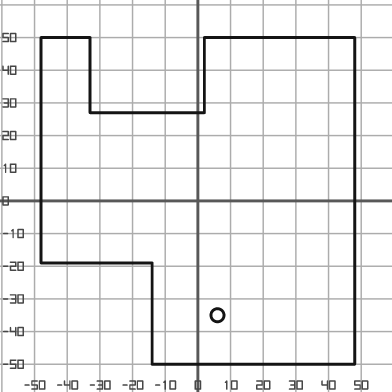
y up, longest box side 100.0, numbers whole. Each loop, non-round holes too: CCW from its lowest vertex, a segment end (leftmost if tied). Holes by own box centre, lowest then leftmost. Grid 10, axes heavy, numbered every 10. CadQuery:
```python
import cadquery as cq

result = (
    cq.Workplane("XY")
    .moveTo(-14.0, -50.0)
    .lineTo(48.0, -50.0)
    .lineTo(48.0, 50.0)
    .lineTo(2.0, 50.0)
    .lineTo(2.0, 27.0)
    .lineTo(-33.0, 27.0)
    .lineTo(-33.0, 50.0)
    .lineTo(-48.0, 50.0)
    .lineTo(-48.0, -19.0)
    .lineTo(-14.0, -19.0)
    .close()
    .moveTo(6.0, -35.0)
    .circle(2.0)
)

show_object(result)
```